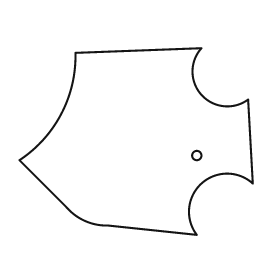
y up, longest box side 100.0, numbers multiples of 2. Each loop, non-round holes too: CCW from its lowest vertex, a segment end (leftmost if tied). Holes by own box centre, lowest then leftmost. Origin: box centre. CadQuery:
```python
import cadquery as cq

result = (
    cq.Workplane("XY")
    .moveTo(26.0, -40.0)
    .threePointArc((28.0, -18.0), (50.0, -18.0))
    .lineTo(48.0, 18.0)
    .threePointArc((28.0, 20.0), (28.0, 40.0))
    .lineTo(-26.0, 38.0)
    .threePointArc((-32.0, 12.0), (-50.0, -8.0))
    .lineTo(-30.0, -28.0)
    .threePointArc((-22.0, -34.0), (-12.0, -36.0))
    .close()
    .moveTo(26.0, -6.0)
    .circle(2.0)
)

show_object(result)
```